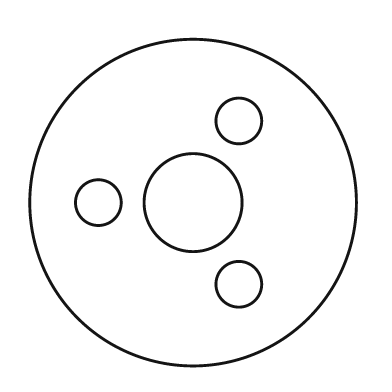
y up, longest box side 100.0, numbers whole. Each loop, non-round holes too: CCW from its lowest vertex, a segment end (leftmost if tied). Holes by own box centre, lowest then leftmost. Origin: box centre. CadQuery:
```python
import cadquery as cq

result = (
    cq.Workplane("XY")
    .moveTo(0.0, 0.0)
    .circle(50.0)
    .moveTo(14.0, -25.0)
    .circle(7.0)
    .moveTo(-29.0, 0.0)
    .circle(7.0)
    .moveTo(0.0, 0.0)
    .circle(15.0)
    .moveTo(14.0, 25.0)
    .circle(7.0)
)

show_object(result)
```